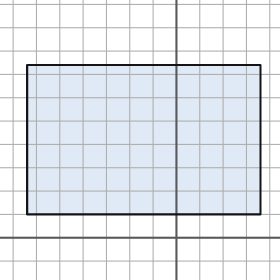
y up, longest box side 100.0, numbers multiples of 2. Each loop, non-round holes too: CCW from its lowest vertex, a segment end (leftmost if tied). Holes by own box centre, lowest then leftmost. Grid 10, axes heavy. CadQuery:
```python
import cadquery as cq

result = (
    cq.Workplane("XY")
    .moveTo(-64.0, 10.0)
    .lineTo(36.0, 10.0)
    .lineTo(36.0, 74.0)
    .lineTo(-64.0, 74.0)
    .close()
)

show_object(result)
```